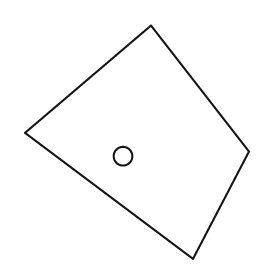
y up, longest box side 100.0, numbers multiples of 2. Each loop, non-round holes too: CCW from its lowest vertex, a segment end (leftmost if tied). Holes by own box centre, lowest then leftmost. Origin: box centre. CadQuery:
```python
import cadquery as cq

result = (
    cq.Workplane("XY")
    .moveTo(24.0, -50.0)
    .lineTo(48.0, -4.0)
    .lineTo(6.0, 50.0)
    .lineTo(-48.0, 4.0)
    .close()
    .moveTo(-6.0, -6.0)
    .circle(4.0)
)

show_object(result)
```